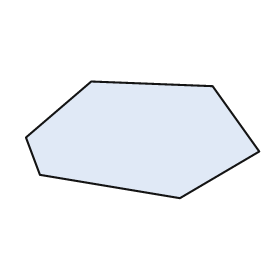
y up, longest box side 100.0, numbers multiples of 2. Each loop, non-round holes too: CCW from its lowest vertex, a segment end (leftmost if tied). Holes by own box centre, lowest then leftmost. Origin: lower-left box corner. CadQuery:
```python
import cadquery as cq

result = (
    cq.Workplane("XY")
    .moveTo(66.0, 0.0)
    .lineTo(100.0, 20.0)
    .lineTo(80.0, 48.0)
    .lineTo(28.0, 50.0)
    .lineTo(0.0, 26.0)
    .lineTo(6.0, 10.0)
    .close()
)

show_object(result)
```